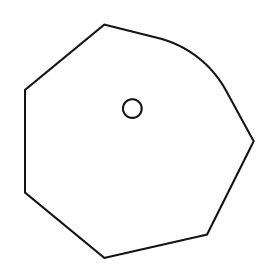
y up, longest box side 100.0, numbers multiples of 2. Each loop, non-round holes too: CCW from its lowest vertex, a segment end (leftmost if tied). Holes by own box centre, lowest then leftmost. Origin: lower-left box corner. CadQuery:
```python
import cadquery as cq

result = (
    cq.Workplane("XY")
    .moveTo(34.0, 0.0)
    .lineTo(78.0, 10.0)
    .lineTo(98.0, 50.0)
    .lineTo(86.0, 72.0)
    .threePointArc((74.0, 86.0), (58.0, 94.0))
    .lineTo(34.0, 100.0)
    .lineTo(0.0, 72.0)
    .lineTo(0.0, 28.0)
    .close()
    .moveTo(46.0, 64.0)
    .circle(4.0)
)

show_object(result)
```